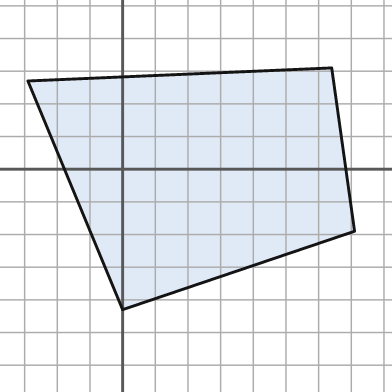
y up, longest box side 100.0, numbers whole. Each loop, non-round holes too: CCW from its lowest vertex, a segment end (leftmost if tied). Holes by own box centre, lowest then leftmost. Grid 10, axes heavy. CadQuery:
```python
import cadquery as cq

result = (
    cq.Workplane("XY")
    .moveTo(0.0, -43.0)
    .lineTo(71.0, -19.0)
    .lineTo(64.0, 31.0)
    .lineTo(-29.0, 27.0)
    .close()
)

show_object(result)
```